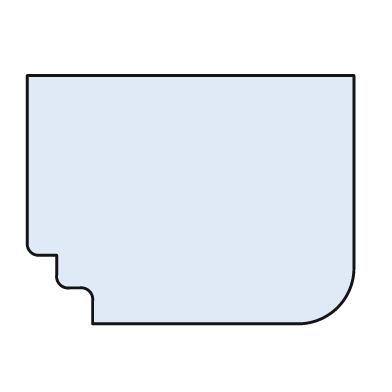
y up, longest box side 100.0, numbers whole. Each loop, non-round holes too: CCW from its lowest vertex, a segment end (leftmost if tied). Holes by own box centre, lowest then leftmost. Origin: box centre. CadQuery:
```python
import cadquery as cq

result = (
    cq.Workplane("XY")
    .moveTo(-30.0, -38.0)
    .lineTo(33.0, -38.0)
    .threePointArc((45.0, -33.0), (50.0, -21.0))
    .lineTo(50.0, 38.0)
    .lineTo(-50.0, 38.0)
    .lineTo(-50.0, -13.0)
    .threePointArc((-49.0, -16.0), (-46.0, -17.0))
    .lineTo(-41.0, -17.0)
    .lineTo(-41.0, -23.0)
    .threePointArc((-40.0, -26.0), (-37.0, -27.0))
    .lineTo(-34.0, -27.0)
    .threePointArc((-31.0, -28.0), (-30.0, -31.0))
    .close()
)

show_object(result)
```